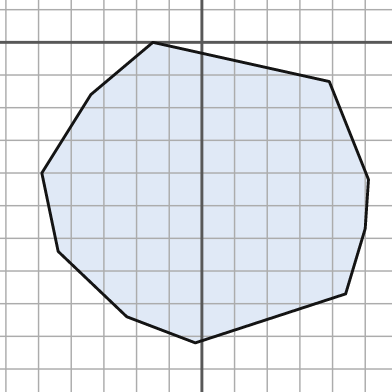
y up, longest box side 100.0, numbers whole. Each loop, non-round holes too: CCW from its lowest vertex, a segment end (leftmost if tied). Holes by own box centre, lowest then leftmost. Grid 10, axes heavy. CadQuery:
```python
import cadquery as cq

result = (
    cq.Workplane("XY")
    .moveTo(-2.0, -92.0)
    .lineTo(44.0, -77.0)
    .lineTo(50.0, -57.0)
    .lineTo(51.0, -42.0)
    .lineTo(39.0, -12.0)
    .lineTo(-15.0, 0.0)
    .lineTo(-34.0, -16.0)
    .lineTo(-49.0, -40.0)
    .lineTo(-44.0, -64.0)
    .lineTo(-23.0, -84.0)
    .close()
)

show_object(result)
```